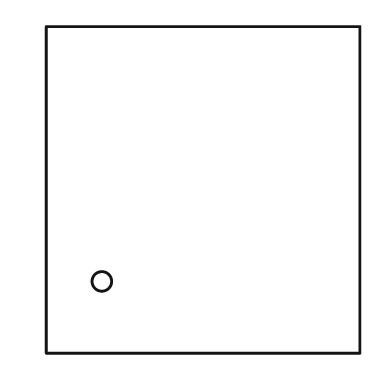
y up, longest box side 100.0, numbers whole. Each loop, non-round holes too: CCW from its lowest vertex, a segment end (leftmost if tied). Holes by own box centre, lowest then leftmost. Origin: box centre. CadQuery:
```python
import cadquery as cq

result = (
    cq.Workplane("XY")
    .moveTo(-48.0, -50.0)
    .lineTo(48.0, -50.0)
    .lineTo(48.0, 50.0)
    .lineTo(-48.0, 50.0)
    .close()
    .moveTo(-31.0, -28.0)
    .circle(3.0)
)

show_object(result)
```